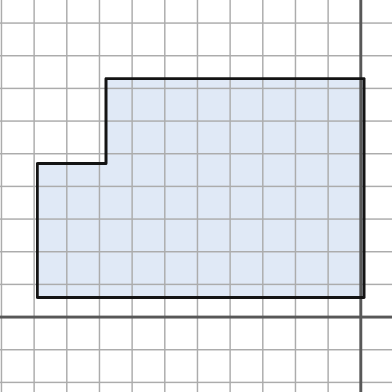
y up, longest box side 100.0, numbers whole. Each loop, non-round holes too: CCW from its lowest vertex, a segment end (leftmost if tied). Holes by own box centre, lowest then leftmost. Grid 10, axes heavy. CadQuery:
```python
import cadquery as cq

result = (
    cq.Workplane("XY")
    .moveTo(-99.0, 6.0)
    .lineTo(1.0, 6.0)
    .lineTo(1.0, 73.0)
    .lineTo(-78.0, 73.0)
    .lineTo(-78.0, 47.0)
    .lineTo(-99.0, 47.0)
    .close()
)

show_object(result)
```